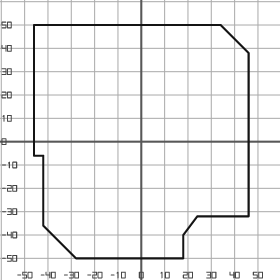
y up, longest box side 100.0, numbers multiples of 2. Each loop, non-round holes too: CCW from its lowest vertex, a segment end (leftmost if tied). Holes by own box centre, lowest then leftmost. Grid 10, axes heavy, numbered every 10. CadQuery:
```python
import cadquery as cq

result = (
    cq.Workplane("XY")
    .moveTo(-28.0, -50.0)
    .lineTo(18.0, -50.0)
    .lineTo(18.0, -40.0)
    .lineTo(24.0, -32.0)
    .lineTo(46.0, -32.0)
    .lineTo(46.0, 38.0)
    .lineTo(34.0, 50.0)
    .lineTo(-46.0, 50.0)
    .lineTo(-46.0, -6.0)
    .lineTo(-42.0, -6.0)
    .lineTo(-42.0, -36.0)
    .close()
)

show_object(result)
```